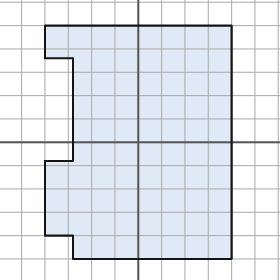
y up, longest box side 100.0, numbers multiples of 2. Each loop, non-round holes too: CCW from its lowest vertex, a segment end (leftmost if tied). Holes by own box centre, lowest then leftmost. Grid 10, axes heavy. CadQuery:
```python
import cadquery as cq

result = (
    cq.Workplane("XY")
    .moveTo(-28.0, -50.0)
    .lineTo(40.0, -50.0)
    .lineTo(40.0, 50.0)
    .lineTo(-40.0, 50.0)
    .lineTo(-40.0, 36.0)
    .lineTo(-28.0, 36.0)
    .lineTo(-28.0, -8.0)
    .lineTo(-40.0, -8.0)
    .lineTo(-40.0, -40.0)
    .lineTo(-28.0, -40.0)
    .close()
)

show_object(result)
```